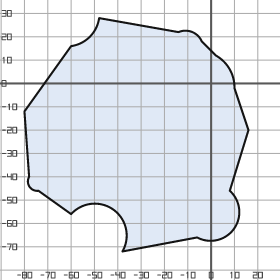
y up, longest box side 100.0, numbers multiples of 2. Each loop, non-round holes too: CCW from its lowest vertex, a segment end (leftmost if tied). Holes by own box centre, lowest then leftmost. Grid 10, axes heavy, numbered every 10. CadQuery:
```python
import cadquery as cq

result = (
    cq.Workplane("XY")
    .moveTo(-38.0, -72.0)
    .lineTo(-6.0, -66.0)
    .threePointArc((10.0, -62.0), (8.0, -46.0))
    .lineTo(16.0, -20.0)
    .lineTo(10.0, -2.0)
    .threePointArc((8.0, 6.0), (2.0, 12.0))
    .lineTo(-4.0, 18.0)
    .threePointArc((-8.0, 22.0), (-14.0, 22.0))
    .lineTo(-48.0, 28.0)
    .threePointArc((-52.0, 20.0), (-60.0, 16.0))
    .lineTo(-80.0, -12.0)
    .lineTo(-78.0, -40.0)
    .threePointArc((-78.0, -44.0), (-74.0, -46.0))
    .lineTo(-60.0, -56.0)
    .threePointArc((-42.0, -54.0), (-38.0, -72.0))
    .close()
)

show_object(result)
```